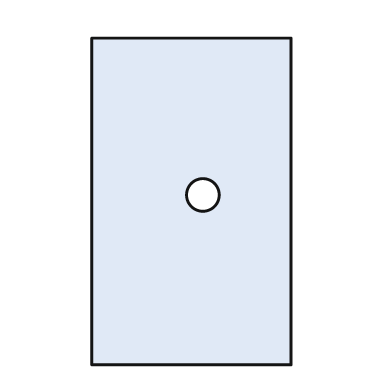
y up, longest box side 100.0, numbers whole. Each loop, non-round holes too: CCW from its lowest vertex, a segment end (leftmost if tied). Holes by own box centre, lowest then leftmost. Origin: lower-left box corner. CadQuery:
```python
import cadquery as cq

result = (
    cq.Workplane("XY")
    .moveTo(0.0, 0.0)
    .lineTo(61.0, 0.0)
    .lineTo(61.0, 100.0)
    .lineTo(0.0, 100.0)
    .close()
    .moveTo(34.0, 52.0)
    .circle(5.0)
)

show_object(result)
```